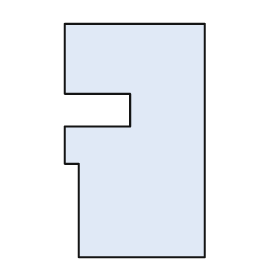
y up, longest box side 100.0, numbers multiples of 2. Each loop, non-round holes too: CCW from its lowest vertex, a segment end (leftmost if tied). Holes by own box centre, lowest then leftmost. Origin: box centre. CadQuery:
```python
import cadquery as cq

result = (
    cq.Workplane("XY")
    .moveTo(-24.0, -50.0)
    .lineTo(30.0, -50.0)
    .lineTo(30.0, 50.0)
    .lineTo(-30.0, 50.0)
    .lineTo(-30.0, 20.0)
    .lineTo(-2.0, 20.0)
    .lineTo(-2.0, 6.0)
    .lineTo(-30.0, 6.0)
    .lineTo(-30.0, -10.0)
    .lineTo(-24.0, -10.0)
    .close()
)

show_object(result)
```